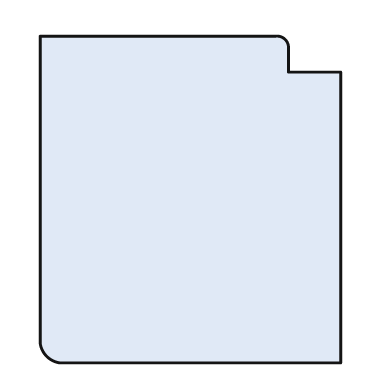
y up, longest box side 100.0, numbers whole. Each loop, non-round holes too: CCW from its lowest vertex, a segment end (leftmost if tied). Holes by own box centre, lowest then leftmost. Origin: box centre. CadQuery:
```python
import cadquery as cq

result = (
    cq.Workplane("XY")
    .moveTo(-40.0, -50.0)
    .lineTo(46.0, -50.0)
    .lineTo(46.0, 39.0)
    .lineTo(30.0, 39.0)
    .lineTo(30.0, 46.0)
    .threePointArc((29.0, 49.0), (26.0, 50.0))
    .lineTo(-46.0, 50.0)
    .lineTo(-46.0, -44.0)
    .threePointArc((-44.0, -48.0), (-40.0, -50.0))
    .close()
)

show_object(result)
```